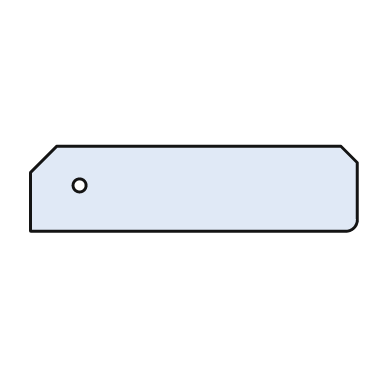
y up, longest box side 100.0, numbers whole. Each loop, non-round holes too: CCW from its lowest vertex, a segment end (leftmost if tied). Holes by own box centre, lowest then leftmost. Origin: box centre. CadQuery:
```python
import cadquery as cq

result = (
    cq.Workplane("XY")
    .moveTo(-50.0, -13.0)
    .lineTo(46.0, -13.0)
    .threePointArc((49.0, -12.0), (50.0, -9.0))
    .lineTo(50.0, 8.0)
    .lineTo(45.0, 13.0)
    .lineTo(-42.0, 13.0)
    .lineTo(-50.0, 5.0)
    .close()
    .moveTo(-35.0, 1.0)
    .circle(2.0)
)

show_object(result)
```